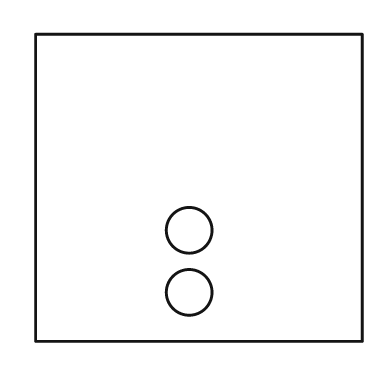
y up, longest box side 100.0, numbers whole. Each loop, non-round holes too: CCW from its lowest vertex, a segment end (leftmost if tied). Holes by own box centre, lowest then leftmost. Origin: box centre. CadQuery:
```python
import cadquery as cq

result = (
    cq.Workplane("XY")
    .moveTo(-50.0, -47.0)
    .lineTo(50.0, -47.0)
    .lineTo(50.0, 47.0)
    .lineTo(-50.0, 47.0)
    .close()
    .moveTo(-3.0, -32.0)
    .circle(7.0)
    .moveTo(-3.0, -13.0)
    .circle(7.0)
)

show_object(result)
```